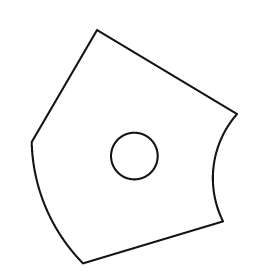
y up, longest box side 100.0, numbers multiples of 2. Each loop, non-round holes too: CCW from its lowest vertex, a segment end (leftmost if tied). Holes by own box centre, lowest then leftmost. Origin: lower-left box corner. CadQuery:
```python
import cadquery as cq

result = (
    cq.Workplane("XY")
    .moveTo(22.0, 0.0)
    .lineTo(82.0, 18.0)
    .threePointArc((78.0, 42.0), (88.0, 64.0))
    .lineTo(28.0, 100.0)
    .lineTo(0.0, 52.0)
    .threePointArc((6.0, 24.0), (22.0, 0.0))
    .close()
    .moveTo(44.0, 46.0)
    .circle(10.0)
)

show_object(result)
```